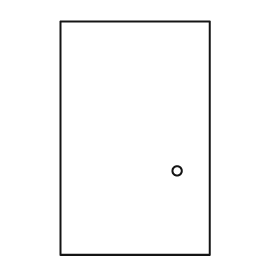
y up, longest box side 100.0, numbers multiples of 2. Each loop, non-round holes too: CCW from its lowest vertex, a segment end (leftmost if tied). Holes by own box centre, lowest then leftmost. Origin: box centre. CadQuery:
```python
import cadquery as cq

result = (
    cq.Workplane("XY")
    .moveTo(-32.0, -50.0)
    .lineTo(32.0, -50.0)
    .lineTo(32.0, 50.0)
    .lineTo(-32.0, 50.0)
    .close()
    .moveTo(18.0, -14.0)
    .circle(2.0)
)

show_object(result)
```